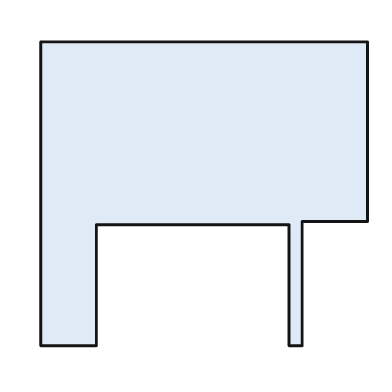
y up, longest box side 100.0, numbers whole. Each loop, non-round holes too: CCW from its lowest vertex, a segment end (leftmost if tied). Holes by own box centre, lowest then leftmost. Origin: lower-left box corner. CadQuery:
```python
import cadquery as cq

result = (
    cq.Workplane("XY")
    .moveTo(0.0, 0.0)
    .lineTo(17.0, 0.0)
    .lineTo(17.0, 37.0)
    .lineTo(76.0, 37.0)
    .lineTo(76.0, 0.0)
    .lineTo(80.0, 0.0)
    .lineTo(80.0, 38.0)
    .lineTo(100.0, 38.0)
    .lineTo(100.0, 93.0)
    .lineTo(0.0, 93.0)
    .close()
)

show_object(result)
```